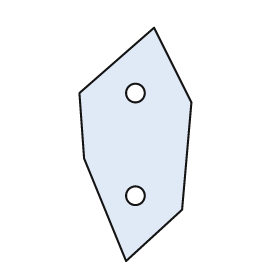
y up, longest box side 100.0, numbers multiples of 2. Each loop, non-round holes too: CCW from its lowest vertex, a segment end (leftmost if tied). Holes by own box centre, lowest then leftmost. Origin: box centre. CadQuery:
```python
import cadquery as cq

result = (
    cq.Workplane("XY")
    .moveTo(-4.0, -50.0)
    .lineTo(20.0, -28.0)
    .lineTo(24.0, 18.0)
    .lineTo(8.0, 50.0)
    .lineTo(-24.0, 22.0)
    .lineTo(-22.0, -6.0)
    .close()
    .moveTo(0.0, -22.0)
    .circle(4.0)
    .moveTo(0.0, 22.0)
    .circle(4.0)
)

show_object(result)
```